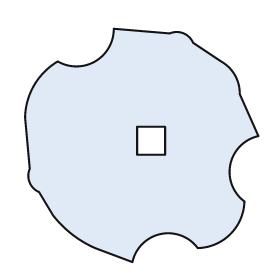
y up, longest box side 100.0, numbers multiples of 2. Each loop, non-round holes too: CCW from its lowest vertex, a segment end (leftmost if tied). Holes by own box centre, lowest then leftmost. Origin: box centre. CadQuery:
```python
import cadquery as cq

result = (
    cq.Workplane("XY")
    .moveTo(-4.0, -50.0)
    .threePointArc((8.0, -38.0), (24.0, -44.0))
    .threePointArc((38.0, -38.0), (44.0, -24.0))
    .threePointArc((38.0, -8.0), (50.0, 4.0))
    .lineTo(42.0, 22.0)
    .threePointArc((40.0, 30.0), (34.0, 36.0))
    .lineTo(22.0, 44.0)
    .threePointArc((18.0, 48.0), (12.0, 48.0))
    .lineTo(-12.0, 50.0)
    .threePointArc((-20.0, 36.0), (-36.0, 36.0))
    .threePointArc((-46.0, 26.0), (-50.0, 12.0))
    .lineTo(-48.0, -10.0)
    .threePointArc((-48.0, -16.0), (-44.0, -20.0))
    .lineTo(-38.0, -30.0)
    .threePointArc((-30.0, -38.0), (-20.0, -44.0))
    .close()
    .moveTo(-2.0, -4.0)
    .lineTo(10.0, -4.0)
    .lineTo(10.0, 8.0)
    .lineTo(-2.0, 8.0)
    .close()
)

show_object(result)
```